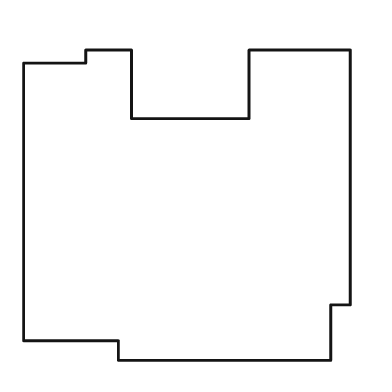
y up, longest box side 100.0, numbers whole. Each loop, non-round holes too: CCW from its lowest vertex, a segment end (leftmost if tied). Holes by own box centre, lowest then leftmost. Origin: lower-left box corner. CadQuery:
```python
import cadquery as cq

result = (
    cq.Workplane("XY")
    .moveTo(29.0, 0.0)
    .lineTo(94.0, 0.0)
    .lineTo(94.0, 17.0)
    .lineTo(100.0, 17.0)
    .lineTo(100.0, 95.0)
    .lineTo(69.0, 95.0)
    .lineTo(69.0, 74.0)
    .lineTo(33.0, 74.0)
    .lineTo(33.0, 95.0)
    .lineTo(19.0, 95.0)
    .lineTo(19.0, 91.0)
    .lineTo(0.0, 91.0)
    .lineTo(0.0, 6.0)
    .lineTo(29.0, 6.0)
    .close()
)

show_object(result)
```